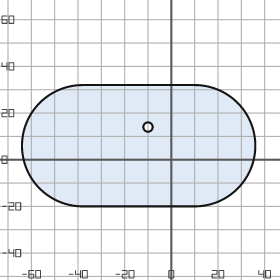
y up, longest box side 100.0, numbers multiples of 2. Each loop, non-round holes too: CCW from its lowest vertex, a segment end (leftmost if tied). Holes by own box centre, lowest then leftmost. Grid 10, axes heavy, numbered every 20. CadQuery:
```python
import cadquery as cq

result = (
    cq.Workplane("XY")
    .moveTo(-38.0, -20.0)
    .lineTo(10.0, -20.0)
    .threePointArc((36.0, 6.0), (10.0, 32.0))
    .lineTo(-38.0, 32.0)
    .threePointArc((-64.0, 6.0), (-38.0, -20.0))
    .close()
    .moveTo(-10.0, 14.0)
    .circle(2.0)
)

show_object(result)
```